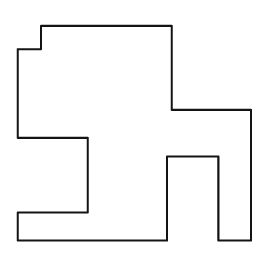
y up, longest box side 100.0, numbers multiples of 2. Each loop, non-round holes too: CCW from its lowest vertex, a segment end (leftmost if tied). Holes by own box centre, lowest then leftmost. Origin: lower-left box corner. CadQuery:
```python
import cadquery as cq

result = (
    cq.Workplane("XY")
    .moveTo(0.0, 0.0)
    .lineTo(64.0, 0.0)
    .lineTo(64.0, 36.0)
    .lineTo(86.0, 36.0)
    .lineTo(86.0, 0.0)
    .lineTo(100.0, 0.0)
    .lineTo(100.0, 56.0)
    .lineTo(66.0, 56.0)
    .lineTo(66.0, 92.0)
    .lineTo(10.0, 92.0)
    .lineTo(10.0, 82.0)
    .lineTo(0.0, 82.0)
    .lineTo(0.0, 44.0)
    .lineTo(30.0, 44.0)
    .lineTo(30.0, 12.0)
    .lineTo(0.0, 12.0)
    .close()
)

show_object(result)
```